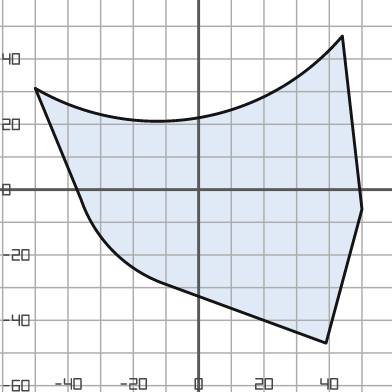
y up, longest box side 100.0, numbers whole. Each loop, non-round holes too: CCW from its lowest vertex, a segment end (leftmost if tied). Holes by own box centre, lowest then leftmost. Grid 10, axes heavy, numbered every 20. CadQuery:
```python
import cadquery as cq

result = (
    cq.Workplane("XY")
    .moveTo(39.0, -47.0)
    .lineTo(50.0, -6.0)
    .lineTo(44.0, 47.0)
    .threePointArc((0.0, 22.0), (-50.0, 31.0))
    .lineTo(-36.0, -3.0)
    .threePointArc((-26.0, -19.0), (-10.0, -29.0))
    .close()
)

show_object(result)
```